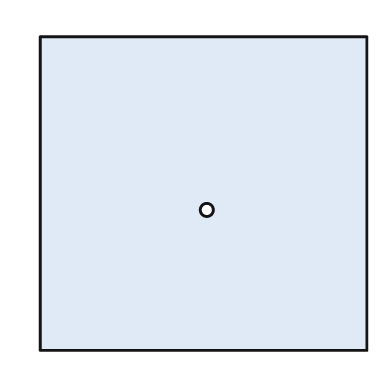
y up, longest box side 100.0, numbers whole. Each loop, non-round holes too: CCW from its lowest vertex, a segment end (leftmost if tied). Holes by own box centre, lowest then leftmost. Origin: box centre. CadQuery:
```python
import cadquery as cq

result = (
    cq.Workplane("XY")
    .moveTo(-50.0, -48.0)
    .lineTo(50.0, -48.0)
    .lineTo(50.0, 48.0)
    .lineTo(-50.0, 48.0)
    .close()
    .moveTo(1.0, -5.0)
    .circle(2.0)
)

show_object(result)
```